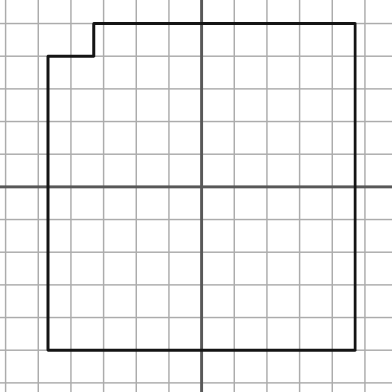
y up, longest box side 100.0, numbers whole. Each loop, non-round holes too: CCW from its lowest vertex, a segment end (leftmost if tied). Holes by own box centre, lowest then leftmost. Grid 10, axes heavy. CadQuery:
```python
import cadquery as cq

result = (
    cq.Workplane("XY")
    .moveTo(-47.0, -50.0)
    .lineTo(47.0, -50.0)
    .lineTo(47.0, 50.0)
    .lineTo(-33.0, 50.0)
    .lineTo(-33.0, 40.0)
    .lineTo(-47.0, 40.0)
    .close()
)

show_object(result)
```